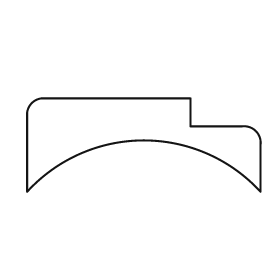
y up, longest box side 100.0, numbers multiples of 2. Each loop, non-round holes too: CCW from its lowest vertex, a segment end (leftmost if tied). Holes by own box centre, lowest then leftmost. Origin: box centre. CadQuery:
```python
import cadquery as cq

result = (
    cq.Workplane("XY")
    .moveTo(-50.0, -20.0)
    .threePointArc((0.0, 2.0), (50.0, -20.0))
    .lineTo(50.0, 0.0)
    .threePointArc((48.0, 6.0), (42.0, 8.0))
    .lineTo(20.0, 8.0)
    .lineTo(20.0, 20.0)
    .lineTo(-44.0, 20.0)
    .threePointArc((-48.0, 18.0), (-50.0, 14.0))
    .close()
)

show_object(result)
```